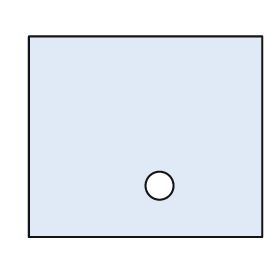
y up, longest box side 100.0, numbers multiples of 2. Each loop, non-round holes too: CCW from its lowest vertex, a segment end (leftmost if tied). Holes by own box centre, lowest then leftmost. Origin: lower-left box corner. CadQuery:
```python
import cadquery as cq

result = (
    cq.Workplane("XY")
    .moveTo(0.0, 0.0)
    .lineTo(100.0, 0.0)
    .lineTo(100.0, 86.0)
    .lineTo(0.0, 86.0)
    .close()
    .moveTo(56.0, 22.0)
    .circle(6.0)
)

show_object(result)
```